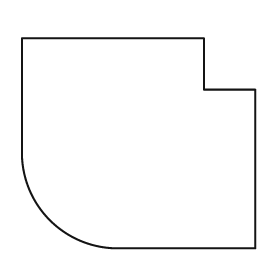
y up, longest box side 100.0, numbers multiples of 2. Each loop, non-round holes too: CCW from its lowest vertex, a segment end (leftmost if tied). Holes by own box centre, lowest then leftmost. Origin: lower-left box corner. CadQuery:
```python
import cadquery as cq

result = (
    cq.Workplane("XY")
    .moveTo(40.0, 0.0)
    .lineTo(100.0, 0.0)
    .lineTo(100.0, 68.0)
    .lineTo(78.0, 68.0)
    .lineTo(78.0, 90.0)
    .lineTo(0.0, 90.0)
    .lineTo(0.0, 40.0)
    .threePointArc((12.0, 12.0), (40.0, 0.0))
    .close()
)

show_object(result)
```